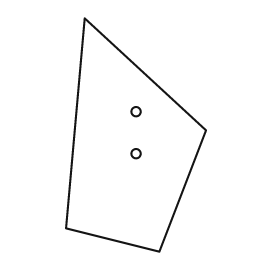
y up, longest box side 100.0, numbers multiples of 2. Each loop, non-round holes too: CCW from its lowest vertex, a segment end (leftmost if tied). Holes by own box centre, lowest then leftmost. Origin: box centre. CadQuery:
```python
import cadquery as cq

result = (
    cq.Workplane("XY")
    .moveTo(10.0, -50.0)
    .lineTo(30.0, 2.0)
    .lineTo(-22.0, 50.0)
    .lineTo(-30.0, -40.0)
    .close()
    .moveTo(0.0, -8.0)
    .circle(2.0)
    .moveTo(0.0, 10.0)
    .circle(2.0)
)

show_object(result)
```